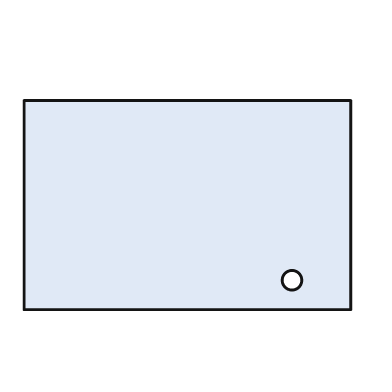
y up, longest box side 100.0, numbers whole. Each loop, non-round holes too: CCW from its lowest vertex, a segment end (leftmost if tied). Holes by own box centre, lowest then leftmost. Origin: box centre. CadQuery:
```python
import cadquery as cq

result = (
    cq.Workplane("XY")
    .moveTo(-50.0, -32.0)
    .lineTo(50.0, -32.0)
    .lineTo(50.0, 32.0)
    .lineTo(-50.0, 32.0)
    .close()
    .moveTo(32.0, -23.0)
    .circle(3.0)
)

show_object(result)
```